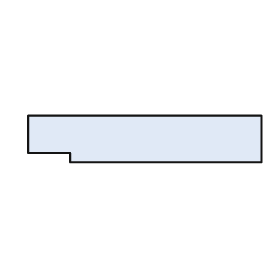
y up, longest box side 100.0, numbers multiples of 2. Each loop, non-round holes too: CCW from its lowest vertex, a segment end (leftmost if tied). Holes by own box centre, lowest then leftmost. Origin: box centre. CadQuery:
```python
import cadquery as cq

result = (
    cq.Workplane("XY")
    .moveTo(-32.0, -10.0)
    .lineTo(50.0, -10.0)
    .lineTo(50.0, 10.0)
    .lineTo(-50.0, 10.0)
    .lineTo(-50.0, -6.0)
    .lineTo(-32.0, -6.0)
    .close()
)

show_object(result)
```